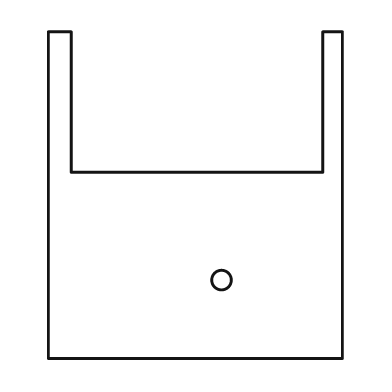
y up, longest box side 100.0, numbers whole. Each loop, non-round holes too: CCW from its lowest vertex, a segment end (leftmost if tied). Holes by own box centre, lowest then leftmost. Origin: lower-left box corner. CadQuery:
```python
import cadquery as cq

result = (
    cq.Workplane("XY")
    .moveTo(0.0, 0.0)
    .lineTo(90.0, 0.0)
    .lineTo(90.0, 100.0)
    .lineTo(84.0, 100.0)
    .lineTo(84.0, 57.0)
    .lineTo(7.0, 57.0)
    .lineTo(7.0, 100.0)
    .lineTo(0.0, 100.0)
    .close()
    .moveTo(53.0, 24.0)
    .circle(3.0)
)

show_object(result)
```